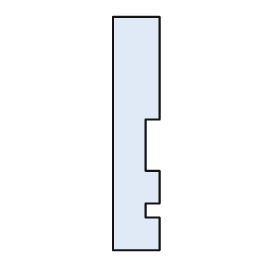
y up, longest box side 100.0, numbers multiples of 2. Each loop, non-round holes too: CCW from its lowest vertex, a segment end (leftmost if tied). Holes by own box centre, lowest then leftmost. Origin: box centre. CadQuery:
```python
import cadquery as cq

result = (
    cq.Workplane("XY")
    .moveTo(-10.0, -50.0)
    .lineTo(10.0, -50.0)
    .lineTo(10.0, -36.0)
    .lineTo(4.0, -36.0)
    .lineTo(4.0, -30.0)
    .lineTo(10.0, -30.0)
    .lineTo(10.0, -16.0)
    .lineTo(4.0, -16.0)
    .lineTo(4.0, 6.0)
    .lineTo(10.0, 6.0)
    .lineTo(10.0, 50.0)
    .lineTo(-10.0, 50.0)
    .close()
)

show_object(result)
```